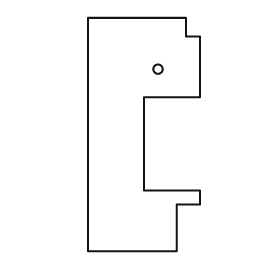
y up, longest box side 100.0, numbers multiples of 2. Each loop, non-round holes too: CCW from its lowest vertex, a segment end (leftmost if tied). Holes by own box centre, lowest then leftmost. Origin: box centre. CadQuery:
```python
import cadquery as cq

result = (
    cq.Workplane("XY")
    .moveTo(-24.0, -50.0)
    .lineTo(14.0, -50.0)
    .lineTo(14.0, -30.0)
    .lineTo(24.0, -30.0)
    .lineTo(24.0, -24.0)
    .lineTo(0.0, -24.0)
    .lineTo(0.0, 16.0)
    .lineTo(24.0, 16.0)
    .lineTo(24.0, 42.0)
    .lineTo(18.0, 42.0)
    .lineTo(18.0, 50.0)
    .lineTo(-24.0, 50.0)
    .close()
    .moveTo(6.0, 28.0)
    .circle(2.0)
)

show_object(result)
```